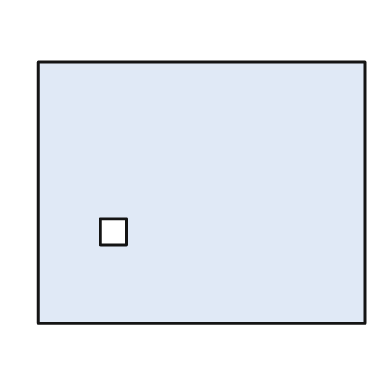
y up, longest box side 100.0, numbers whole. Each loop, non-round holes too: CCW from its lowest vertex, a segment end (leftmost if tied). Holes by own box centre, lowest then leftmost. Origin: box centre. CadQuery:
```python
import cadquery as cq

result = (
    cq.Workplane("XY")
    .moveTo(-50.0, -40.0)
    .lineTo(50.0, -40.0)
    .lineTo(50.0, 40.0)
    .lineTo(-50.0, 40.0)
    .close()
    .moveTo(-31.0, -16.0)
    .lineTo(-23.0, -16.0)
    .lineTo(-23.0, -8.0)
    .lineTo(-31.0, -8.0)
    .close()
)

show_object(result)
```